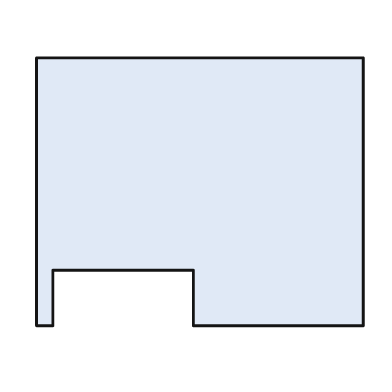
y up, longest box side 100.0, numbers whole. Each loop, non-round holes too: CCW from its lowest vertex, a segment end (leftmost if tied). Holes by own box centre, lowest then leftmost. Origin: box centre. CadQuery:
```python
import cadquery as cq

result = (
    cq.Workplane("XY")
    .moveTo(-50.0, -41.0)
    .lineTo(-45.0, -41.0)
    .lineTo(-45.0, -24.0)
    .lineTo(-2.0, -24.0)
    .lineTo(-2.0, -41.0)
    .lineTo(50.0, -41.0)
    .lineTo(50.0, 41.0)
    .lineTo(-50.0, 41.0)
    .close()
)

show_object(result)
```